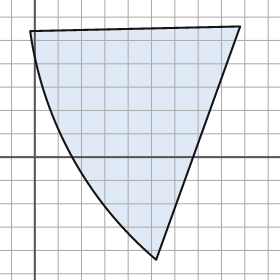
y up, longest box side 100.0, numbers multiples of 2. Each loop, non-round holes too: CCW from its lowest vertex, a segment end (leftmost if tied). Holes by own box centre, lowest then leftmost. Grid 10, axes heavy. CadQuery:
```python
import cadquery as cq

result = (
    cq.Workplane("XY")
    .moveTo(52.0, -44.0)
    .lineTo(88.0, 56.0)
    .lineTo(-2.0, 54.0)
    .threePointArc((16.0, 0.0), (52.0, -44.0))
    .close()
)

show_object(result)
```